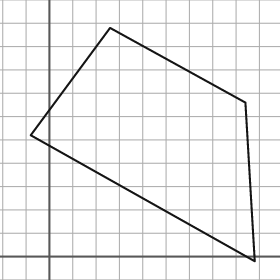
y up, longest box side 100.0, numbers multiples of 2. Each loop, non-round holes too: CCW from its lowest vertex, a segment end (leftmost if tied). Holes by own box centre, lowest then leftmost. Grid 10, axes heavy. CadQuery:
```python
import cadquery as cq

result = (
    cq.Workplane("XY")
    .moveTo(88.0, -2.0)
    .lineTo(84.0, 66.0)
    .lineTo(26.0, 98.0)
    .lineTo(-8.0, 52.0)
    .close()
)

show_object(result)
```